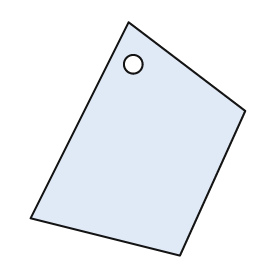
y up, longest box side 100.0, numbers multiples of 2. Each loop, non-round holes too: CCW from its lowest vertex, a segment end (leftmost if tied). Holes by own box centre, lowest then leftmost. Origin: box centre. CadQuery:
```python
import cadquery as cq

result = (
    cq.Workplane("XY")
    .moveTo(18.0, -50.0)
    .lineTo(46.0, 12.0)
    .lineTo(-4.0, 50.0)
    .lineTo(-46.0, -34.0)
    .close()
    .moveTo(-2.0, 32.0)
    .circle(4.0)
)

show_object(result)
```